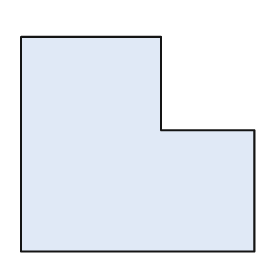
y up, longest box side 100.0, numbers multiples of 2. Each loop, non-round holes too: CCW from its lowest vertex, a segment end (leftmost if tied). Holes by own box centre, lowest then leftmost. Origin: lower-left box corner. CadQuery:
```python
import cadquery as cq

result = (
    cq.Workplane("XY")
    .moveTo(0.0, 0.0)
    .lineTo(100.0, 0.0)
    .lineTo(100.0, 52.0)
    .lineTo(60.0, 52.0)
    .lineTo(60.0, 92.0)
    .lineTo(0.0, 92.0)
    .close()
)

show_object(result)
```